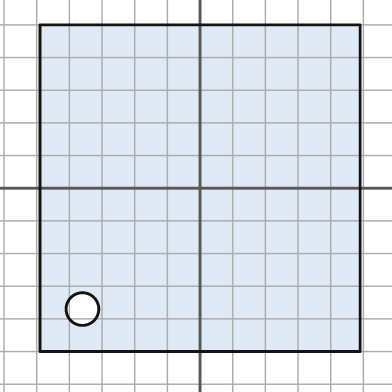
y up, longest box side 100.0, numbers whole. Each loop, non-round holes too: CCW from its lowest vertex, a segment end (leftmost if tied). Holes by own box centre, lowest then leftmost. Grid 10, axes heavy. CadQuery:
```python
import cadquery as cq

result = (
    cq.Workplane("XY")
    .moveTo(-49.0, -50.0)
    .lineTo(49.0, -50.0)
    .lineTo(49.0, 50.0)
    .lineTo(-49.0, 50.0)
    .close()
    .moveTo(-36.0, -37.0)
    .circle(5.0)
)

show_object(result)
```